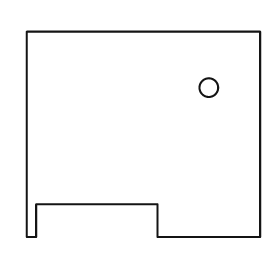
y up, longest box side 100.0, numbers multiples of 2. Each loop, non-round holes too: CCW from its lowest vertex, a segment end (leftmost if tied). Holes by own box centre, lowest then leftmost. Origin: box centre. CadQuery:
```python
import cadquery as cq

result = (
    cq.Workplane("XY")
    .moveTo(-50.0, -44.0)
    .lineTo(-46.0, -44.0)
    .lineTo(-46.0, -30.0)
    .lineTo(6.0, -30.0)
    .lineTo(6.0, -44.0)
    .lineTo(50.0, -44.0)
    .lineTo(50.0, 44.0)
    .lineTo(-50.0, 44.0)
    .close()
    .moveTo(28.0, 20.0)
    .circle(4.0)
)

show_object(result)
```